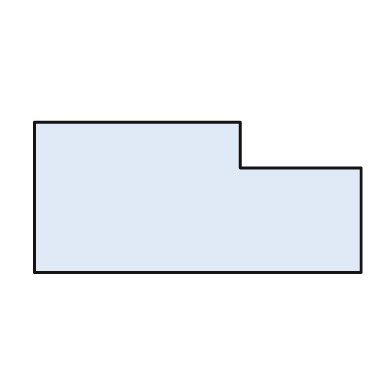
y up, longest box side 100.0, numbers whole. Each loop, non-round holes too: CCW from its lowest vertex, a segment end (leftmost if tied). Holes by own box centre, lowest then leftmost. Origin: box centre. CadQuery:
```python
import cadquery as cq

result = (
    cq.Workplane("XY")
    .moveTo(-50.0, -23.0)
    .lineTo(50.0, -23.0)
    .lineTo(50.0, 9.0)
    .lineTo(13.0, 9.0)
    .lineTo(13.0, 23.0)
    .lineTo(-50.0, 23.0)
    .close()
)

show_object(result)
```